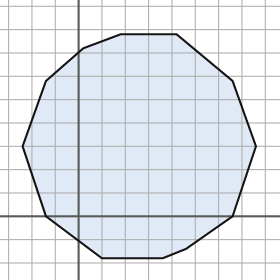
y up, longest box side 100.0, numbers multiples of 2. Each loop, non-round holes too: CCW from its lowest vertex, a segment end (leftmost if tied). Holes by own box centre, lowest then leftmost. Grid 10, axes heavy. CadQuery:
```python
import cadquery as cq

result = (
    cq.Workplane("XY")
    .moveTo(10.0, -18.0)
    .lineTo(36.0, -18.0)
    .lineTo(46.0, -14.0)
    .lineTo(66.0, 0.0)
    .lineTo(76.0, 30.0)
    .lineTo(66.0, 58.0)
    .lineTo(42.0, 78.0)
    .lineTo(18.0, 78.0)
    .lineTo(2.0, 72.0)
    .lineTo(-14.0, 58.0)
    .lineTo(-24.0, 30.0)
    .lineTo(-14.0, 0.0)
    .close()
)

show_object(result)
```